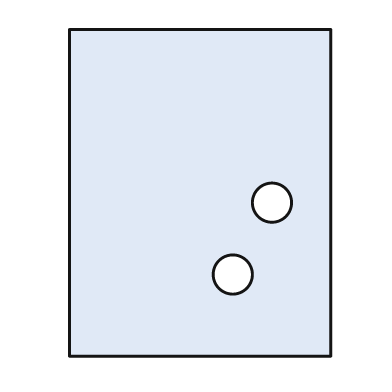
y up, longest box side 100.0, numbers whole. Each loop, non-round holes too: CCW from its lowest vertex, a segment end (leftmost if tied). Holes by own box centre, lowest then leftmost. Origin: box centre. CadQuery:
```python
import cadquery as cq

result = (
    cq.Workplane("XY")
    .moveTo(-40.0, -50.0)
    .lineTo(40.0, -50.0)
    .lineTo(40.0, 50.0)
    .lineTo(-40.0, 50.0)
    .close()
    .moveTo(10.0, -25.0)
    .circle(6.0)
    .moveTo(22.0, -3.0)
    .circle(6.0)
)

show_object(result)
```